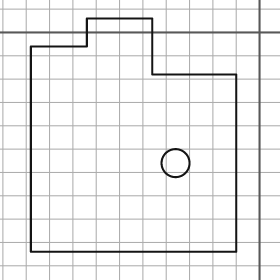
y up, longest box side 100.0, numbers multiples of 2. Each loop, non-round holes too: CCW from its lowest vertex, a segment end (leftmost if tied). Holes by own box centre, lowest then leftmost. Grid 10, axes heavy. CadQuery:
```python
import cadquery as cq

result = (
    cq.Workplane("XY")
    .moveTo(-98.0, -94.0)
    .lineTo(-10.0, -94.0)
    .lineTo(-10.0, -18.0)
    .lineTo(-46.0, -18.0)
    .lineTo(-46.0, 6.0)
    .lineTo(-74.0, 6.0)
    .lineTo(-74.0, -6.0)
    .lineTo(-98.0, -6.0)
    .close()
    .moveTo(-36.0, -56.0)
    .circle(6.0)
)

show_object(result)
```